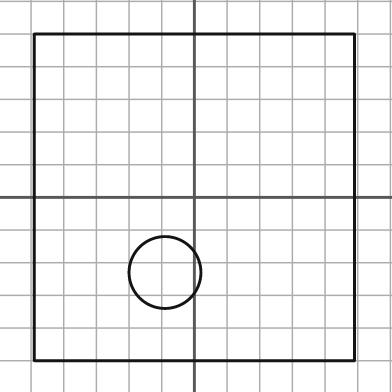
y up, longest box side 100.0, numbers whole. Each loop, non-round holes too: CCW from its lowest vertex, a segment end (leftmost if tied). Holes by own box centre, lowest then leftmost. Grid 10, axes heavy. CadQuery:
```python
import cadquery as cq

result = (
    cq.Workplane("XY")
    .moveTo(-49.0, -50.0)
    .lineTo(49.0, -50.0)
    .lineTo(49.0, 50.0)
    .lineTo(-49.0, 50.0)
    .close()
    .moveTo(-9.0, -23.0)
    .circle(11.0)
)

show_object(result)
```